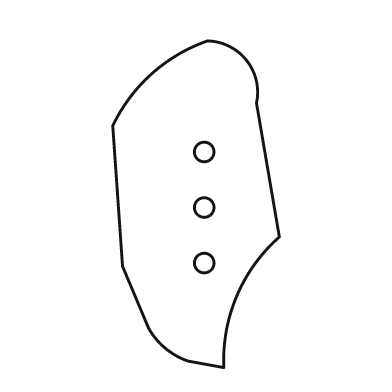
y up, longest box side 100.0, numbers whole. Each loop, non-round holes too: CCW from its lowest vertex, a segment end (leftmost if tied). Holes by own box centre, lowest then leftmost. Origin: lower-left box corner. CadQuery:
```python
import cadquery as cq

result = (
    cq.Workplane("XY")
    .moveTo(34.0, 0.0)
    .threePointArc((38.0, 22.0), (51.0, 40.0))
    .lineTo(44.0, 81.0)
    .threePointArc((41.0, 94.0), (29.0, 100.0))
    .threePointArc((12.0, 90.0), (0.0, 74.0))
    .lineTo(3.0, 31.0)
    .lineTo(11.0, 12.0)
    .threePointArc((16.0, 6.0), (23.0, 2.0))
    .close()
    .moveTo(28.0, 32.0)
    .circle(3.0)
    .moveTo(28.0, 49.0)
    .circle(3.0)
    .moveTo(28.0, 66.0)
    .circle(3.0)
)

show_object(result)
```